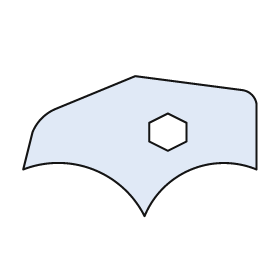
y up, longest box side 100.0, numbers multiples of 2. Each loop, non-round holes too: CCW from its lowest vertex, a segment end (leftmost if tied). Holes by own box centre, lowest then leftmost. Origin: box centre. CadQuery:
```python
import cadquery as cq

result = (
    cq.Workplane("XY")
    .moveTo(2.0, -30.0)
    .threePointArc((22.0, -10.0), (50.0, -10.0))
    .lineTo(50.0, 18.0)
    .threePointArc((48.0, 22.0), (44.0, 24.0))
    .lineTo(-2.0, 30.0)
    .lineTo(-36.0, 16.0)
    .threePointArc((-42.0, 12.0), (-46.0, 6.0))
    .lineTo(-50.0, -10.0)
    .threePointArc((-20.0, -10.0), (2.0, -30.0))
    .close()
    .moveTo(12.0, -2.0)
    .lineTo(20.0, 2.0)
    .lineTo(20.0, 10.0)
    .lineTo(12.0, 14.0)
    .lineTo(4.0, 10.0)
    .lineTo(4.0, 2.0)
    .close()
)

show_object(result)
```